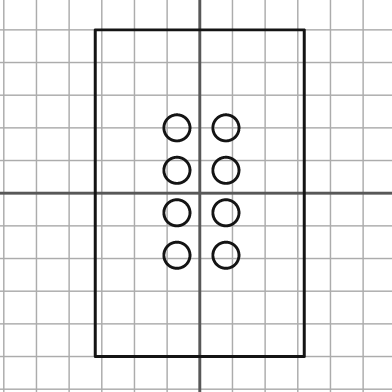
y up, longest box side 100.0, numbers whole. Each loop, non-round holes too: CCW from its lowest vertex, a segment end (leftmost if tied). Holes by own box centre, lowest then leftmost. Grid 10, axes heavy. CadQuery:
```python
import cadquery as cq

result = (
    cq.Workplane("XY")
    .moveTo(-32.0, -50.0)
    .lineTo(32.0, -50.0)
    .lineTo(32.0, 50.0)
    .lineTo(-32.0, 50.0)
    .close()
    .moveTo(-7.0, -19.0)
    .circle(4.0)
    .moveTo(8.0, -19.0)
    .circle(4.0)
    .moveTo(-7.0, -6.0)
    .circle(4.0)
    .moveTo(8.0, -6.0)
    .circle(4.0)
    .moveTo(-7.0, 7.0)
    .circle(4.0)
    .moveTo(8.0, 7.0)
    .circle(4.0)
    .moveTo(-7.0, 20.0)
    .circle(4.0)
    .moveTo(8.0, 20.0)
    .circle(4.0)
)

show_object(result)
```